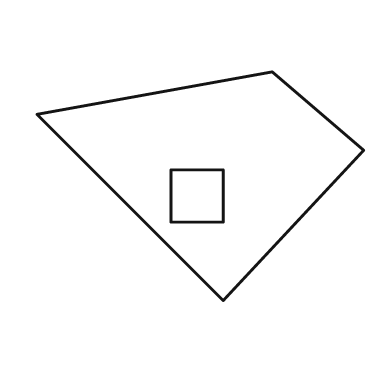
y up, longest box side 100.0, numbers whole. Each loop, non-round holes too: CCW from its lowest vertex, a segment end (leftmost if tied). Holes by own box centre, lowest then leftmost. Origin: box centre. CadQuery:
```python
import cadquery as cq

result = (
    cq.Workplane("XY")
    .moveTo(7.0, -35.0)
    .lineTo(50.0, 11.0)
    .lineTo(22.0, 35.0)
    .lineTo(-50.0, 22.0)
    .close()
    .moveTo(-9.0, -11.0)
    .lineTo(7.0, -11.0)
    .lineTo(7.0, 5.0)
    .lineTo(-9.0, 5.0)
    .close()
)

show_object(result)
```